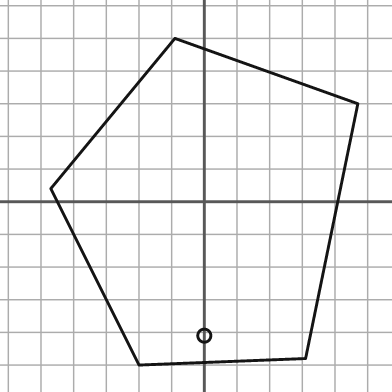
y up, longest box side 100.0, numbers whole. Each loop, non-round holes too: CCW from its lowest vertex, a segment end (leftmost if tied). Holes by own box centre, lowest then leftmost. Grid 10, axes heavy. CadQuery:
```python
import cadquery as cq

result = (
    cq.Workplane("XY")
    .moveTo(-20.0, -50.0)
    .lineTo(31.0, -48.0)
    .lineTo(47.0, 30.0)
    .lineTo(-9.0, 50.0)
    .lineTo(-47.0, 4.0)
    .close()
    .moveTo(0.0, -41.0)
    .circle(2.0)
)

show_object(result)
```